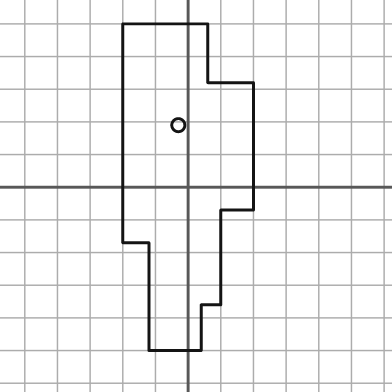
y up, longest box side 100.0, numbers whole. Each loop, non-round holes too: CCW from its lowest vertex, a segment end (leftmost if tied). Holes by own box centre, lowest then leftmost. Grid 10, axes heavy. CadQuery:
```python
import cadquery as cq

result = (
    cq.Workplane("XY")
    .moveTo(-12.0, -50.0)
    .lineTo(4.0, -50.0)
    .lineTo(4.0, -36.0)
    .lineTo(10.0, -36.0)
    .lineTo(10.0, -7.0)
    .lineTo(20.0, -7.0)
    .lineTo(20.0, 32.0)
    .lineTo(6.0, 32.0)
    .lineTo(6.0, 50.0)
    .lineTo(-20.0, 50.0)
    .lineTo(-20.0, -17.0)
    .lineTo(-12.0, -17.0)
    .close()
    .moveTo(-3.0, 19.0)
    .circle(2.0)
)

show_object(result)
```